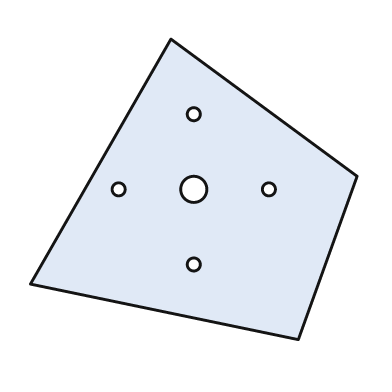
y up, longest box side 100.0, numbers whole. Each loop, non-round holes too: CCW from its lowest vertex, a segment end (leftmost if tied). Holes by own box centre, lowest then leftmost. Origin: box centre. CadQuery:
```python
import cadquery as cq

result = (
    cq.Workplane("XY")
    .moveTo(32.0, -46.0)
    .lineTo(50.0, 4.0)
    .lineTo(-7.0, 46.0)
    .lineTo(-50.0, -29.0)
    .close()
    .moveTo(0.0, -23.0)
    .circle(2.0)
    .moveTo(-23.0, 0.0)
    .circle(2.0)
    .moveTo(0.0, 0.0)
    .circle(4.0)
    .moveTo(23.0, 0.0)
    .circle(2.0)
    .moveTo(0.0, 23.0)
    .circle(2.0)
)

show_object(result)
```